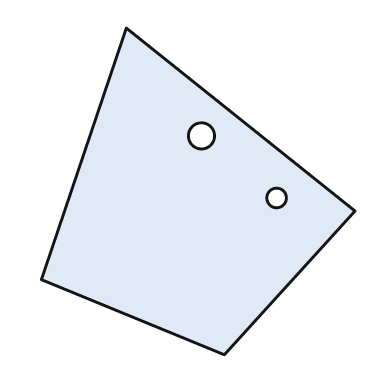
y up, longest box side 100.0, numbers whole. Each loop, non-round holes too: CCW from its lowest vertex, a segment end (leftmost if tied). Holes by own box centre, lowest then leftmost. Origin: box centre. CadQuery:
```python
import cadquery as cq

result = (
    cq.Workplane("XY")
    .moveTo(8.0, -50.0)
    .lineTo(48.0, -6.0)
    .lineTo(-22.0, 50.0)
    .lineTo(-48.0, -27.0)
    .close()
    .moveTo(24.0, -2.0)
    .circle(3.0)
    .moveTo(1.0, 17.0)
    .circle(4.0)
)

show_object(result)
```